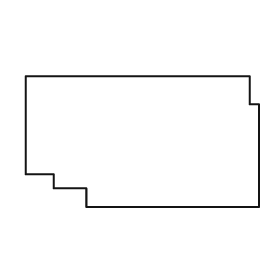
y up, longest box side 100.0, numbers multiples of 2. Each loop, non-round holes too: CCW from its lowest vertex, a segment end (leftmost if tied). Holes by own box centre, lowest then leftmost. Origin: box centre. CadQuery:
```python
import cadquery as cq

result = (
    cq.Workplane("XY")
    .moveTo(-24.0, -28.0)
    .lineTo(50.0, -28.0)
    .lineTo(50.0, 16.0)
    .lineTo(46.0, 16.0)
    .lineTo(46.0, 28.0)
    .lineTo(-50.0, 28.0)
    .lineTo(-50.0, -14.0)
    .lineTo(-38.0, -14.0)
    .lineTo(-38.0, -20.0)
    .lineTo(-24.0, -20.0)
    .close()
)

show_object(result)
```